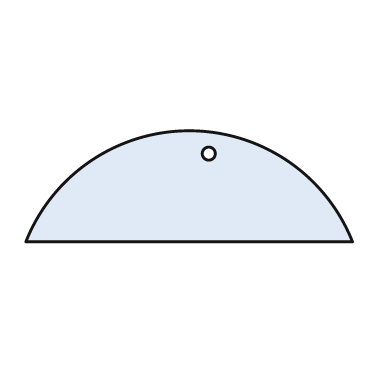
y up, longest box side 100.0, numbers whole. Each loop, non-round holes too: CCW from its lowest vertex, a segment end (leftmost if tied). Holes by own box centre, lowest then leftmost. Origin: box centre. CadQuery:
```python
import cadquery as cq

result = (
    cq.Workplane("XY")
    .moveTo(-50.0, -17.0)
    .lineTo(50.0, -17.0)
    .threePointArc((0.0, 17.0), (-50.0, -17.0))
    .close()
    .moveTo(6.0, 10.0)
    .circle(2.0)
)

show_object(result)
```